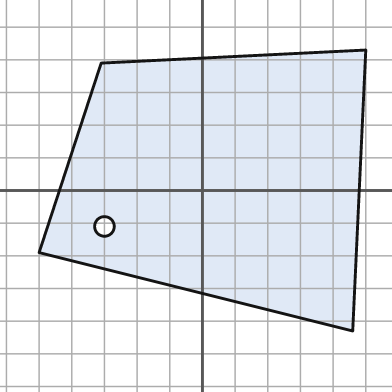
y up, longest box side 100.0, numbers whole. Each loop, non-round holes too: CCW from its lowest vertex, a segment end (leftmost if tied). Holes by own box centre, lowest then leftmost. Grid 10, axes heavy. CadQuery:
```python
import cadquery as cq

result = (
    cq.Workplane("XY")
    .moveTo(46.0, -43.0)
    .lineTo(50.0, 43.0)
    .lineTo(-31.0, 39.0)
    .lineTo(-50.0, -19.0)
    .close()
    .moveTo(-30.0, -11.0)
    .circle(3.0)
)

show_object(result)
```